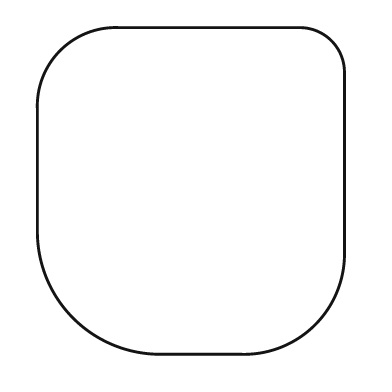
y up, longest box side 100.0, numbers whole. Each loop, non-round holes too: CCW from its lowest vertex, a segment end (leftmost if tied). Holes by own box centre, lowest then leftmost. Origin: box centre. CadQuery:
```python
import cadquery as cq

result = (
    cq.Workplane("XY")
    .moveTo(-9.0, -50.0)
    .lineTo(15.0, -50.0)
    .threePointArc((38.0, -41.0), (47.0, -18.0))
    .lineTo(47.0, 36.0)
    .threePointArc((43.0, 46.0), (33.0, 50.0))
    .lineTo(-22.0, 50.0)
    .threePointArc((-40.0, 43.0), (-47.0, 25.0))
    .lineTo(-47.0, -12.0)
    .threePointArc((-36.0, -39.0), (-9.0, -50.0))
    .close()
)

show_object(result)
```